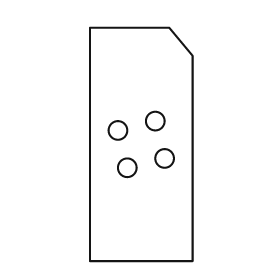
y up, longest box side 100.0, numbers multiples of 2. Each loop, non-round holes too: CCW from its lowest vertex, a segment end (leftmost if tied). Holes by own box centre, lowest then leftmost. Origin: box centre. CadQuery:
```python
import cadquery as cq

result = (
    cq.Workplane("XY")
    .moveTo(-22.0, -50.0)
    .lineTo(22.0, -50.0)
    .lineTo(22.0, 38.0)
    .lineTo(12.0, 50.0)
    .lineTo(-22.0, 50.0)
    .close()
    .moveTo(-6.0, -10.0)
    .circle(4.0)
    .moveTo(10.0, -6.0)
    .circle(4.0)
    .moveTo(-10.0, 6.0)
    .circle(4.0)
    .moveTo(6.0, 10.0)
    .circle(4.0)
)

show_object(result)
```